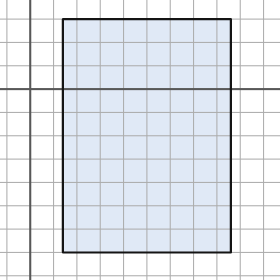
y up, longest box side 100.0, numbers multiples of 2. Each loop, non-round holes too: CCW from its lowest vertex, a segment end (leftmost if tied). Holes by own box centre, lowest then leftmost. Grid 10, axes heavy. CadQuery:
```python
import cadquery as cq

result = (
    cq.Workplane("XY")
    .moveTo(14.0, -70.0)
    .lineTo(86.0, -70.0)
    .lineTo(86.0, 30.0)
    .lineTo(14.0, 30.0)
    .close()
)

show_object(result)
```